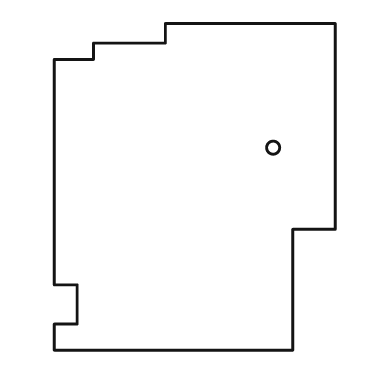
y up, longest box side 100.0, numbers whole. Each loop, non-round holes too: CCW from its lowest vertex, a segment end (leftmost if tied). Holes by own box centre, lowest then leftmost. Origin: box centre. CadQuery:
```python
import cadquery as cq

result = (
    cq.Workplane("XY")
    .moveTo(-43.0, -50.0)
    .lineTo(30.0, -50.0)
    .lineTo(30.0, -13.0)
    .lineTo(43.0, -13.0)
    .lineTo(43.0, 50.0)
    .lineTo(-9.0, 50.0)
    .lineTo(-9.0, 44.0)
    .lineTo(-31.0, 44.0)
    .lineTo(-31.0, 39.0)
    .lineTo(-43.0, 39.0)
    .lineTo(-43.0, -30.0)
    .lineTo(-36.0, -30.0)
    .lineTo(-36.0, -42.0)
    .lineTo(-43.0, -42.0)
    .close()
    .moveTo(24.0, 12.0)
    .circle(2.0)
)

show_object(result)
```